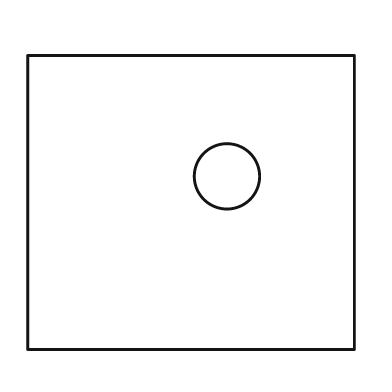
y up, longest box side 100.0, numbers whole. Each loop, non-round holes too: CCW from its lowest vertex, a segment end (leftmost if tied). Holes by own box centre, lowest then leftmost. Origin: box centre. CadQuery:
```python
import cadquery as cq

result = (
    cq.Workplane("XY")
    .moveTo(-50.0, -45.0)
    .lineTo(50.0, -45.0)
    .lineTo(50.0, 45.0)
    .lineTo(-50.0, 45.0)
    .close()
    .moveTo(11.0, 8.0)
    .circle(10.0)
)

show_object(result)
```